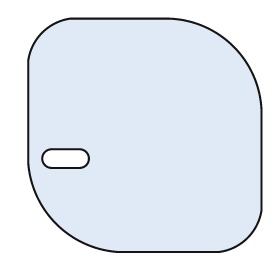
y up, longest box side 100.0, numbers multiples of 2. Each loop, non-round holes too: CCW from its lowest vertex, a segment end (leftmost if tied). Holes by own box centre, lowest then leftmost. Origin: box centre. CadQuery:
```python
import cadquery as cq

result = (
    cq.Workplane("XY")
    .moveTo(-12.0, -50.0)
    .lineTo(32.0, -50.0)
    .threePointArc((44.0, -44.0), (50.0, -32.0))
    .lineTo(50.0, 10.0)
    .threePointArc((38.0, 38.0), (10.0, 50.0))
    .lineTo(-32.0, 50.0)
    .threePointArc((-44.0, 44.0), (-50.0, 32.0))
    .lineTo(-50.0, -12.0)
    .threePointArc((-38.0, -38.0), (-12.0, -50.0))
    .close()
    .moveTo(-40.0, -14.0)
    .lineTo(-28.0, -14.0)
    .threePointArc((-24.0, -10.0), (-28.0, -6.0))
    .lineTo(-40.0, -6.0)
    .threePointArc((-44.0, -10.0), (-40.0, -14.0))
    .close()
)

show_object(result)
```